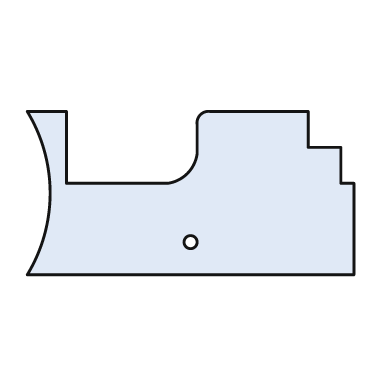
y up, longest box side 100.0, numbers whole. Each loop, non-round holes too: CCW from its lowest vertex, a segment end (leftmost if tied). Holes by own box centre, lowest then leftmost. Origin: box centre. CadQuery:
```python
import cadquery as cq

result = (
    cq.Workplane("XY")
    .moveTo(-50.0, -25.0)
    .lineTo(50.0, -25.0)
    .lineTo(50.0, 3.0)
    .lineTo(46.0, 3.0)
    .lineTo(46.0, 14.0)
    .lineTo(36.0, 14.0)
    .lineTo(36.0, 25.0)
    .lineTo(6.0, 25.0)
    .threePointArc((3.0, 24.0), (2.0, 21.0))
    .lineTo(2.0, 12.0)
    .threePointArc((-1.0, 6.0), (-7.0, 3.0))
    .lineTo(-38.0, 3.0)
    .lineTo(-38.0, 25.0)
    .lineTo(-50.0, 25.0)
    .threePointArc((-43.0, 0.0), (-50.0, -25.0))
    .close()
    .moveTo(0.0, -15.0)
    .circle(2.0)
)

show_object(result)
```